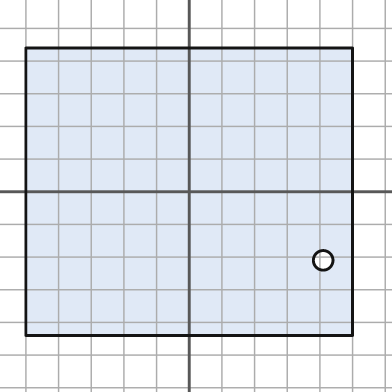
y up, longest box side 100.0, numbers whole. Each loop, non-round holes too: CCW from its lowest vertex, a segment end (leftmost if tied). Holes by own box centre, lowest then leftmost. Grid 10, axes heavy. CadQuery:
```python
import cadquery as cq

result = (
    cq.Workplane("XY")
    .moveTo(-50.0, -44.0)
    .lineTo(50.0, -44.0)
    .lineTo(50.0, 44.0)
    .lineTo(-50.0, 44.0)
    .close()
    .moveTo(41.0, -21.0)
    .circle(3.0)
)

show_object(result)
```